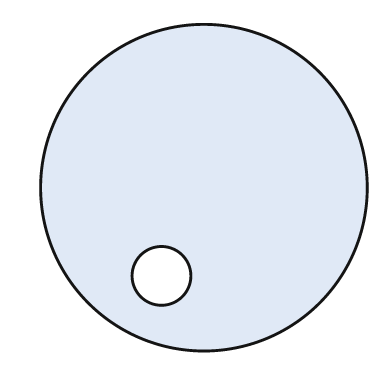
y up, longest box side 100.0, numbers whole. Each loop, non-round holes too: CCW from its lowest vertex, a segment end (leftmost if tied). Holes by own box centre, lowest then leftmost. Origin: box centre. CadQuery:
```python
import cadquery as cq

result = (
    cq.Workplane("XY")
    .moveTo(0.0, 0.0)
    .circle(50.0)
    .moveTo(-13.0, -27.0)
    .circle(9.0)
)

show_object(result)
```